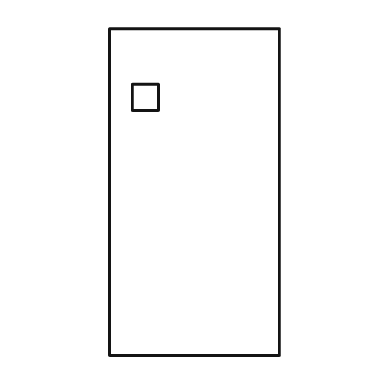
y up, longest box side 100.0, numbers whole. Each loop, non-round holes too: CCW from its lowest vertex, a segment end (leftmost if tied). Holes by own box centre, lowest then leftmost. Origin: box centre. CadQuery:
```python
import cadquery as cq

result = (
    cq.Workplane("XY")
    .moveTo(-26.0, -50.0)
    .lineTo(26.0, -50.0)
    .lineTo(26.0, 50.0)
    .lineTo(-26.0, 50.0)
    .close()
    .moveTo(-19.0, 25.0)
    .lineTo(-11.0, 25.0)
    .lineTo(-11.0, 33.0)
    .lineTo(-19.0, 33.0)
    .close()
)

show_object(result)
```